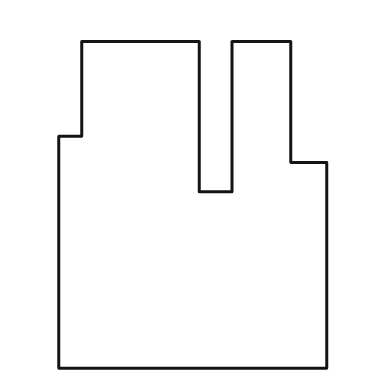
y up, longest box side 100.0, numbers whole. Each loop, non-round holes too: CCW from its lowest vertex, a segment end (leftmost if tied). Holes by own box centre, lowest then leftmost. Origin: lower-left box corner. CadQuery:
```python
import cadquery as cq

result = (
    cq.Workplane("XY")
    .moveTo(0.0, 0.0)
    .lineTo(82.0, 0.0)
    .lineTo(82.0, 63.0)
    .lineTo(71.0, 63.0)
    .lineTo(71.0, 100.0)
    .lineTo(53.0, 100.0)
    .lineTo(53.0, 54.0)
    .lineTo(43.0, 54.0)
    .lineTo(43.0, 100.0)
    .lineTo(7.0, 100.0)
    .lineTo(7.0, 71.0)
    .lineTo(0.0, 71.0)
    .close()
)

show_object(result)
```